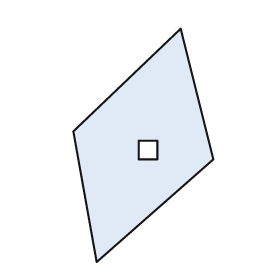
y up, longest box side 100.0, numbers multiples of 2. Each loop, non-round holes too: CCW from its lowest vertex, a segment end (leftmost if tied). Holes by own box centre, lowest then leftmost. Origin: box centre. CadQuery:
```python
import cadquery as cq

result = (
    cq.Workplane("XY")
    .moveTo(-20.0, -50.0)
    .lineTo(30.0, -6.0)
    .lineTo(16.0, 50.0)
    .lineTo(-30.0, 6.0)
    .close()
    .moveTo(-2.0, -6.0)
    .lineTo(6.0, -6.0)
    .lineTo(6.0, 2.0)
    .lineTo(-2.0, 2.0)
    .close()
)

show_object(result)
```